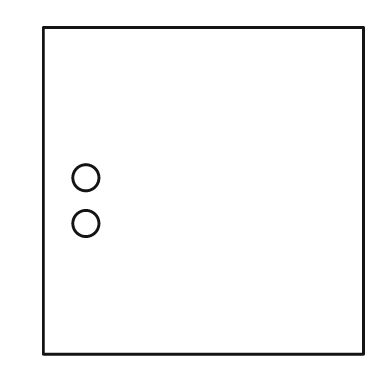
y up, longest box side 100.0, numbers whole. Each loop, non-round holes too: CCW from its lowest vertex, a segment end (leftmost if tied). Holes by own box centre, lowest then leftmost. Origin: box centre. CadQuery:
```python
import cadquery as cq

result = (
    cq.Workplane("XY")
    .moveTo(-49.0, -50.0)
    .lineTo(49.0, -50.0)
    .lineTo(49.0, 50.0)
    .lineTo(-49.0, 50.0)
    .close()
    .moveTo(-36.0, -10.0)
    .circle(4.0)
    .moveTo(-36.0, 4.0)
    .circle(4.0)
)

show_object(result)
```